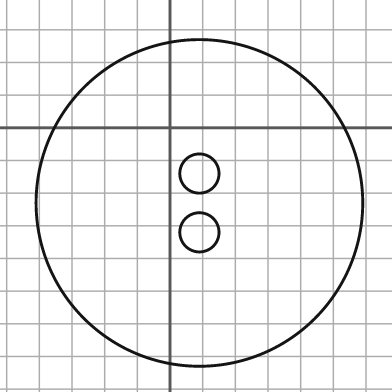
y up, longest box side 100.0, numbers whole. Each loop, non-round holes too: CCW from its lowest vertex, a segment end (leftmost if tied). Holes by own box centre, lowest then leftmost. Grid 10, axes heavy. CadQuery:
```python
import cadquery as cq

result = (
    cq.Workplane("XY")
    .moveTo(9.0, -23.0)
    .circle(50.0)
    .moveTo(9.0, -32.0)
    .circle(6.0)
    .moveTo(9.0, -14.0)
    .circle(6.0)
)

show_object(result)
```